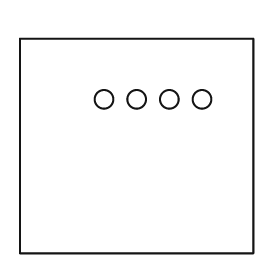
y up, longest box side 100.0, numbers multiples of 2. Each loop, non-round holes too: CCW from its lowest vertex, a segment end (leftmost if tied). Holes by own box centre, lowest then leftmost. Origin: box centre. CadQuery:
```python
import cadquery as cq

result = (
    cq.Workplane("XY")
    .moveTo(-50.0, -46.0)
    .lineTo(50.0, -46.0)
    .lineTo(50.0, 46.0)
    .lineTo(-50.0, 46.0)
    .close()
    .moveTo(-14.0, 20.0)
    .circle(4.0)
    .moveTo(0.0, 20.0)
    .circle(4.0)
    .moveTo(14.0, 20.0)
    .circle(4.0)
    .moveTo(28.0, 20.0)
    .circle(4.0)
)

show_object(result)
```